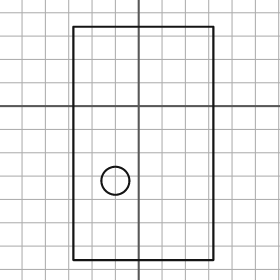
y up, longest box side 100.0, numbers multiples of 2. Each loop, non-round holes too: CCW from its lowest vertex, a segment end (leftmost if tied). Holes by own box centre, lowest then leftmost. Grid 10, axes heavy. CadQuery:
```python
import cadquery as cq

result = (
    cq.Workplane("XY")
    .moveTo(-28.0, -66.0)
    .lineTo(32.0, -66.0)
    .lineTo(32.0, 34.0)
    .lineTo(-28.0, 34.0)
    .close()
    .moveTo(-10.0, -32.0)
    .circle(6.0)
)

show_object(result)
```